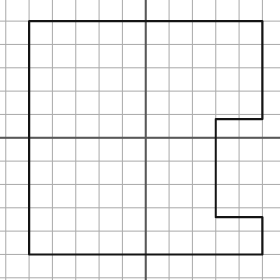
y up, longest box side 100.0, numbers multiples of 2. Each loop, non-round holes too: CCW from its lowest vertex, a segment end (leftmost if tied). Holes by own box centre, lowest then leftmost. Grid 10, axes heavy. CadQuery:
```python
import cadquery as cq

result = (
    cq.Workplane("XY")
    .moveTo(-50.0, -50.0)
    .lineTo(50.0, -50.0)
    .lineTo(50.0, -34.0)
    .lineTo(30.0, -34.0)
    .lineTo(30.0, 8.0)
    .lineTo(50.0, 8.0)
    .lineTo(50.0, 50.0)
    .lineTo(-50.0, 50.0)
    .close()
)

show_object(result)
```